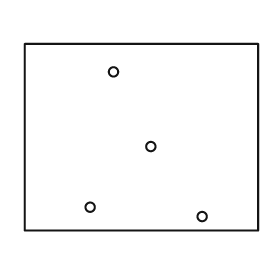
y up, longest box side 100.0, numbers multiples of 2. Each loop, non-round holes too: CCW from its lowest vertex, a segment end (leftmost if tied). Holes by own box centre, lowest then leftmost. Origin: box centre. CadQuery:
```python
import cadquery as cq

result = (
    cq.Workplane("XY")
    .moveTo(-50.0, -40.0)
    .lineTo(50.0, -40.0)
    .lineTo(50.0, 40.0)
    .lineTo(-50.0, 40.0)
    .close()
    .moveTo(26.0, -34.0)
    .circle(2.0)
    .moveTo(-22.0, -30.0)
    .circle(2.0)
    .moveTo(4.0, -4.0)
    .circle(2.0)
    .moveTo(-12.0, 28.0)
    .circle(2.0)
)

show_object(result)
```